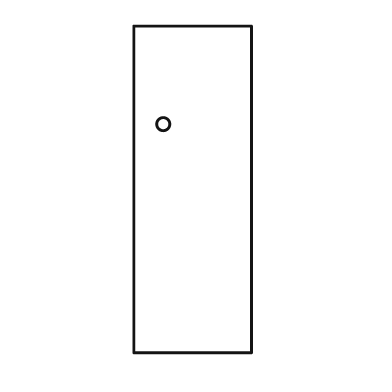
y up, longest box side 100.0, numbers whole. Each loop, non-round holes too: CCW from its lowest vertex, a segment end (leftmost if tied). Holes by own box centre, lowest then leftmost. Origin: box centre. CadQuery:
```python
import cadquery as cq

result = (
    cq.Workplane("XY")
    .moveTo(-18.0, -50.0)
    .lineTo(18.0, -50.0)
    .lineTo(18.0, 50.0)
    .lineTo(-18.0, 50.0)
    .close()
    .moveTo(-9.0, 20.0)
    .circle(2.0)
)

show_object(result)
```